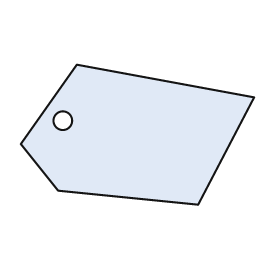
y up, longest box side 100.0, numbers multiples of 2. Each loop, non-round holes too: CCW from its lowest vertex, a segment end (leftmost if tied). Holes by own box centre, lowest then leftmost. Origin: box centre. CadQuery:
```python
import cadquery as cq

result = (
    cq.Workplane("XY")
    .moveTo(26.0, -30.0)
    .lineTo(50.0, 16.0)
    .lineTo(-26.0, 30.0)
    .lineTo(-50.0, -4.0)
    .lineTo(-34.0, -24.0)
    .close()
    .moveTo(-32.0, 6.0)
    .circle(4.0)
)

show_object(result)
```